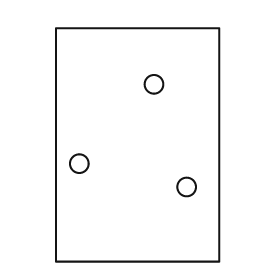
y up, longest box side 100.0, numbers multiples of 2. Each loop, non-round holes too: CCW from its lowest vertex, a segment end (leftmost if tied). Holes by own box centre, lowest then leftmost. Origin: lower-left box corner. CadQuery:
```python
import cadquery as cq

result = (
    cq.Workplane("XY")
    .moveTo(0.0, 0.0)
    .lineTo(70.0, 0.0)
    .lineTo(70.0, 100.0)
    .lineTo(0.0, 100.0)
    .close()
    .moveTo(56.0, 32.0)
    .circle(4.0)
    .moveTo(10.0, 42.0)
    .circle(4.0)
    .moveTo(42.0, 76.0)
    .circle(4.0)
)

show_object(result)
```